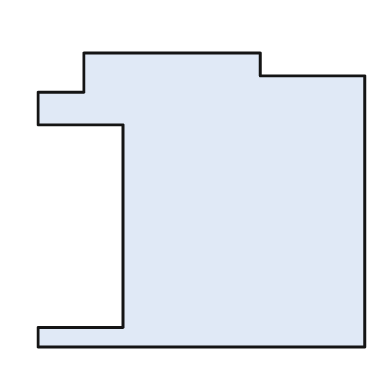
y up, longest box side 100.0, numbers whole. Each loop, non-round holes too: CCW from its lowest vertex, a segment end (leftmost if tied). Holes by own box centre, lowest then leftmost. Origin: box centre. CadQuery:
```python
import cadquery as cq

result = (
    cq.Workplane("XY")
    .moveTo(-50.0, -45.0)
    .lineTo(50.0, -45.0)
    .lineTo(50.0, 38.0)
    .lineTo(18.0, 38.0)
    .lineTo(18.0, 45.0)
    .lineTo(-36.0, 45.0)
    .lineTo(-36.0, 33.0)
    .lineTo(-50.0, 33.0)
    .lineTo(-50.0, 23.0)
    .lineTo(-24.0, 23.0)
    .lineTo(-24.0, -39.0)
    .lineTo(-50.0, -39.0)
    .close()
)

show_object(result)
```